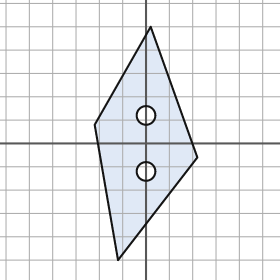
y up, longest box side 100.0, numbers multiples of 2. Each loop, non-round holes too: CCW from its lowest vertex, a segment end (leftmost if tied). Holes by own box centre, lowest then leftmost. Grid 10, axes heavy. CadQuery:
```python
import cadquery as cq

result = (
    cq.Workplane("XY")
    .moveTo(-12.0, -50.0)
    .lineTo(22.0, -6.0)
    .lineTo(2.0, 50.0)
    .lineTo(-22.0, 8.0)
    .close()
    .moveTo(0.0, -12.0)
    .circle(4.0)
    .moveTo(0.0, 12.0)
    .circle(4.0)
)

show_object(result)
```